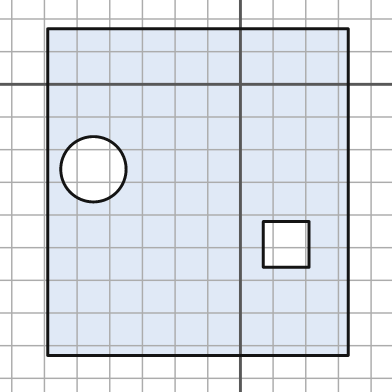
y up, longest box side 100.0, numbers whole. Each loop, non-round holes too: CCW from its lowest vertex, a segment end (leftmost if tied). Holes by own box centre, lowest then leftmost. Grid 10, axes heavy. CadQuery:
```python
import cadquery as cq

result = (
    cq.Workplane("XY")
    .moveTo(-59.0, -83.0)
    .lineTo(33.0, -83.0)
    .lineTo(33.0, 17.0)
    .lineTo(-59.0, 17.0)
    .close()
    .moveTo(7.0, -56.0)
    .lineTo(21.0, -56.0)
    .lineTo(21.0, -42.0)
    .lineTo(7.0, -42.0)
    .close()
    .moveTo(-45.0, -26.0)
    .circle(10.0)
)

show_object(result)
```